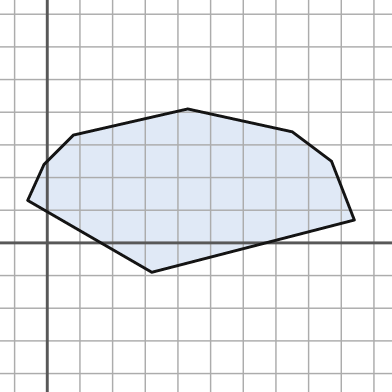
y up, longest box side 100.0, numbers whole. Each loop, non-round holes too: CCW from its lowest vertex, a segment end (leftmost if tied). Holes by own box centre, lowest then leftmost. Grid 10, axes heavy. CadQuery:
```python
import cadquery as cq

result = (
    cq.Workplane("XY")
    .moveTo(32.0, -9.0)
    .lineTo(94.0, 7.0)
    .lineTo(87.0, 25.0)
    .lineTo(75.0, 34.0)
    .lineTo(43.0, 41.0)
    .lineTo(8.0, 33.0)
    .lineTo(-1.0, 24.0)
    .lineTo(-6.0, 13.0)
    .close()
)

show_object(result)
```